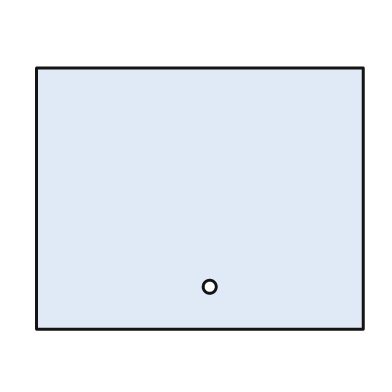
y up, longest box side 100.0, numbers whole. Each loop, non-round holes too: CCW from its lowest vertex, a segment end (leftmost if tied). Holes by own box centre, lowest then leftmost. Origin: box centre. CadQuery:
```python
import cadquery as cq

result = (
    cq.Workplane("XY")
    .moveTo(-50.0, -40.0)
    .lineTo(50.0, -40.0)
    .lineTo(50.0, 40.0)
    .lineTo(-50.0, 40.0)
    .close()
    .moveTo(3.0, -27.0)
    .circle(2.0)
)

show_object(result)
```